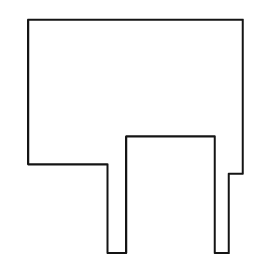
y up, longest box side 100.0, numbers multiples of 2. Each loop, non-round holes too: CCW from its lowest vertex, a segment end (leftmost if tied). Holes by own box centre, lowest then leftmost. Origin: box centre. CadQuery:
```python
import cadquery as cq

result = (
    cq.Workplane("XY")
    .moveTo(-12.0, -50.0)
    .lineTo(-4.0, -50.0)
    .lineTo(-4.0, 0.0)
    .lineTo(34.0, 0.0)
    .lineTo(34.0, -50.0)
    .lineTo(40.0, -50.0)
    .lineTo(40.0, -16.0)
    .lineTo(46.0, -16.0)
    .lineTo(46.0, 50.0)
    .lineTo(-46.0, 50.0)
    .lineTo(-46.0, -12.0)
    .lineTo(-12.0, -12.0)
    .close()
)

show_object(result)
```